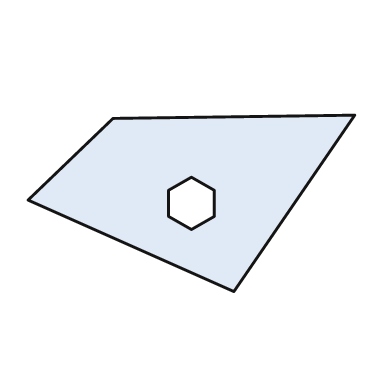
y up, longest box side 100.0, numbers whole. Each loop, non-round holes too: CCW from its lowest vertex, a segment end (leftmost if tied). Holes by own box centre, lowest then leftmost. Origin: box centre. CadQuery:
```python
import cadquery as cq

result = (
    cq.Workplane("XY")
    .moveTo(13.0, -27.0)
    .lineTo(50.0, 27.0)
    .lineTo(-24.0, 26.0)
    .lineTo(-50.0, 1.0)
    .close()
    .moveTo(0.0, -8.0)
    .lineTo(7.0, -4.0)
    .lineTo(7.0, 4.0)
    .lineTo(0.0, 8.0)
    .lineTo(-7.0, 4.0)
    .lineTo(-7.0, -4.0)
    .close()
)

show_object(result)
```